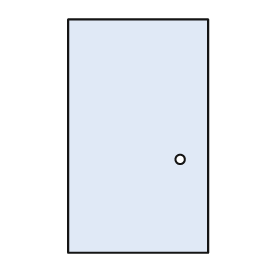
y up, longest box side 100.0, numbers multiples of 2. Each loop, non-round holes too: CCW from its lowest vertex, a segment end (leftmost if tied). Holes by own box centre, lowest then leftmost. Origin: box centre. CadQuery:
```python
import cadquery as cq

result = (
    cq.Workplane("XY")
    .moveTo(-30.0, -50.0)
    .lineTo(30.0, -50.0)
    .lineTo(30.0, 50.0)
    .lineTo(-30.0, 50.0)
    .close()
    .moveTo(18.0, -10.0)
    .circle(2.0)
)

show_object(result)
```